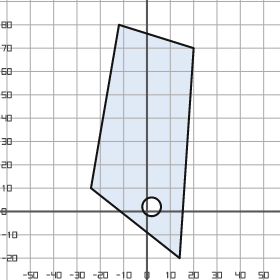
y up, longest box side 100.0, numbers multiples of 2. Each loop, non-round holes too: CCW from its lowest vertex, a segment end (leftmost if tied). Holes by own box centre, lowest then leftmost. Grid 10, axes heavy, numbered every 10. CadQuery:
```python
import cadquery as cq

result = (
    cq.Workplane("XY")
    .moveTo(14.0, -20.0)
    .lineTo(20.0, 70.0)
    .lineTo(-12.0, 80.0)
    .lineTo(-24.0, 10.0)
    .close()
    .moveTo(2.0, 2.0)
    .circle(4.0)
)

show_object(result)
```